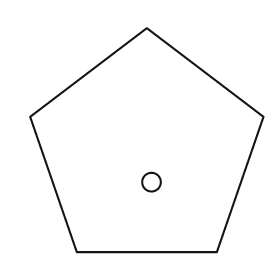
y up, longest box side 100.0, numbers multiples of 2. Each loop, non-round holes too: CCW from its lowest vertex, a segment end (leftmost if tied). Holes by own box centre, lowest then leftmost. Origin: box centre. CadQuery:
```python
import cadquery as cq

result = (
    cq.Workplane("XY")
    .moveTo(-30.0, -48.0)
    .lineTo(30.0, -48.0)
    .lineTo(50.0, 10.0)
    .lineTo(0.0, 48.0)
    .lineTo(-50.0, 10.0)
    .close()
    .moveTo(2.0, -18.0)
    .circle(4.0)
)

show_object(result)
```